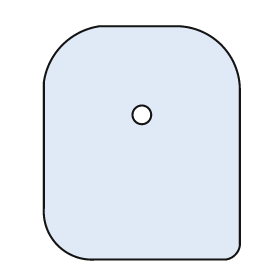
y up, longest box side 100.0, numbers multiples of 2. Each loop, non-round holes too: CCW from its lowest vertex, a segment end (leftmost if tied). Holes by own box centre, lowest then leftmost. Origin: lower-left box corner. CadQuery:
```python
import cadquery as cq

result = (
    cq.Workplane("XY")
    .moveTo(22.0, 0.0)
    .lineTo(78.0, 0.0)
    .threePointArc((82.0, 2.0), (84.0, 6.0))
    .lineTo(84.0, 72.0)
    .threePointArc((76.0, 92.0), (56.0, 100.0))
    .lineTo(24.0, 100.0)
    .threePointArc((8.0, 92.0), (0.0, 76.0))
    .lineTo(0.0, 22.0)
    .threePointArc((6.0, 6.0), (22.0, 0.0))
    .close()
    .moveTo(42.0, 62.0)
    .circle(4.0)
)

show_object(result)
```